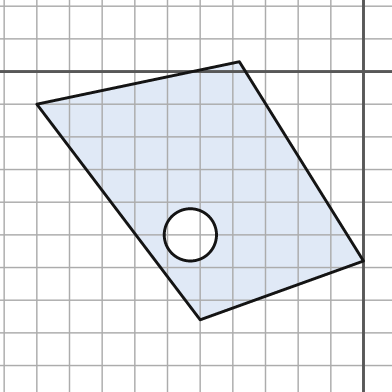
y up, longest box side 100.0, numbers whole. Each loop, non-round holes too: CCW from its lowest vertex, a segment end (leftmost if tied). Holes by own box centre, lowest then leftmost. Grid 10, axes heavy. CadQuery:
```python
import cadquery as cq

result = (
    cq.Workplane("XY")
    .moveTo(-50.0, -76.0)
    .lineTo(0.0, -58.0)
    .lineTo(-38.0, 3.0)
    .lineTo(-100.0, -10.0)
    .close()
    .moveTo(-53.0, -50.0)
    .circle(8.0)
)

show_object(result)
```